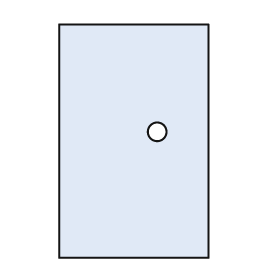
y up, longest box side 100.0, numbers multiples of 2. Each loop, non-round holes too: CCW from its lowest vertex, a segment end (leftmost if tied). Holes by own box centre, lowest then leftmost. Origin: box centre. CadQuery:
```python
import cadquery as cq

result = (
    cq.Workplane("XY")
    .moveTo(-32.0, -50.0)
    .lineTo(32.0, -50.0)
    .lineTo(32.0, 50.0)
    .lineTo(-32.0, 50.0)
    .close()
    .moveTo(10.0, 4.0)
    .circle(4.0)
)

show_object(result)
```